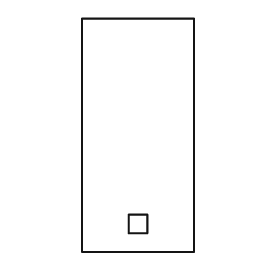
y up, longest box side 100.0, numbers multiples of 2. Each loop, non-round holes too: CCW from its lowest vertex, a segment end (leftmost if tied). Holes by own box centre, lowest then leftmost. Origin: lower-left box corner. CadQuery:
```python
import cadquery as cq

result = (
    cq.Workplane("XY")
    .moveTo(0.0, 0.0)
    .lineTo(48.0, 0.0)
    .lineTo(48.0, 100.0)
    .lineTo(0.0, 100.0)
    .close()
    .moveTo(20.0, 8.0)
    .lineTo(28.0, 8.0)
    .lineTo(28.0, 16.0)
    .lineTo(20.0, 16.0)
    .close()
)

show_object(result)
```